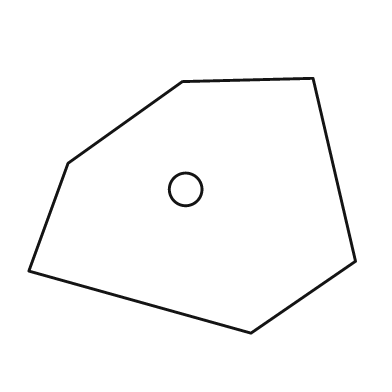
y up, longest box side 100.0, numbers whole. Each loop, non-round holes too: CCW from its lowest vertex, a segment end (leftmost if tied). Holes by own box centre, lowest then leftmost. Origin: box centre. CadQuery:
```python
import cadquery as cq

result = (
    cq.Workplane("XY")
    .moveTo(18.0, -39.0)
    .lineTo(50.0, -17.0)
    .lineTo(37.0, 39.0)
    .lineTo(-3.0, 38.0)
    .lineTo(-38.0, 13.0)
    .lineTo(-50.0, -20.0)
    .close()
    .moveTo(-2.0, 5.0)
    .circle(5.0)
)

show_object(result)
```